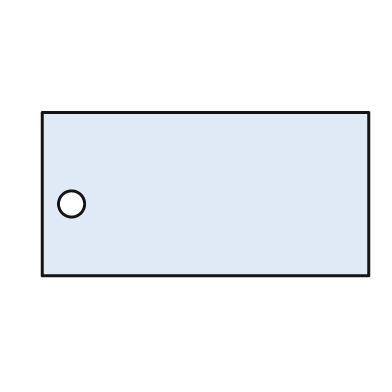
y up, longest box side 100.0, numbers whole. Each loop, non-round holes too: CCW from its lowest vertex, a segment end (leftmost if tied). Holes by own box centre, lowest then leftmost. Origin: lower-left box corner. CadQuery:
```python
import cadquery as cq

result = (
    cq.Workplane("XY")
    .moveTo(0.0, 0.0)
    .lineTo(100.0, 0.0)
    .lineTo(100.0, 50.0)
    .lineTo(0.0, 50.0)
    .close()
    .moveTo(9.0, 22.0)
    .circle(4.0)
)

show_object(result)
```